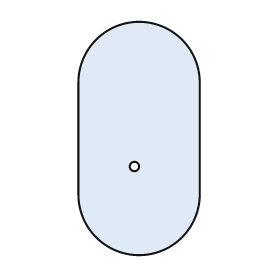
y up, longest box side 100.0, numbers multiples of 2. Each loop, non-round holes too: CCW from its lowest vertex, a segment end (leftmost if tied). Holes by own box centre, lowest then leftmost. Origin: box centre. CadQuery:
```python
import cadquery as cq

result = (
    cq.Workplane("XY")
    .moveTo(-26.0, -24.0)
    .threePointArc((0.0, -50.0), (26.0, -24.0))
    .lineTo(26.0, 24.0)
    .threePointArc((0.0, 50.0), (-26.0, 24.0))
    .close()
    .moveTo(-2.0, -12.0)
    .circle(2.0)
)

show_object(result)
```